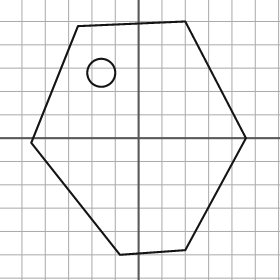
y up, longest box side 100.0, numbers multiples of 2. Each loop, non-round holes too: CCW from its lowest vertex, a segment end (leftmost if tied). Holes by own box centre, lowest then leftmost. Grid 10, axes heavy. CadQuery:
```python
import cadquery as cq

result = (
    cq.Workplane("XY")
    .moveTo(-8.0, -50.0)
    .lineTo(20.0, -48.0)
    .lineTo(46.0, 0.0)
    .lineTo(20.0, 50.0)
    .lineTo(-26.0, 48.0)
    .lineTo(-46.0, -2.0)
    .close()
    .moveTo(-16.0, 28.0)
    .circle(6.0)
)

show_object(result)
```